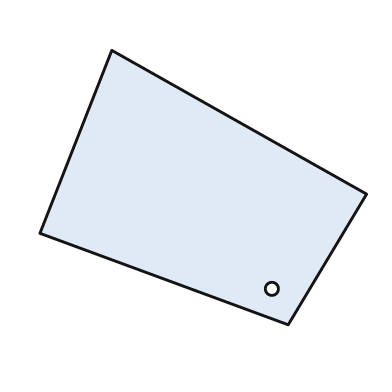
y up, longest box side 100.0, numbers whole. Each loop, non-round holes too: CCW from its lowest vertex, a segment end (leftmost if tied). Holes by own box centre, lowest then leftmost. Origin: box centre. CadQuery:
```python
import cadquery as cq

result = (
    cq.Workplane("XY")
    .moveTo(26.0, -42.0)
    .lineTo(50.0, -2.0)
    .lineTo(-28.0, 42.0)
    .lineTo(-50.0, -14.0)
    .close()
    .moveTo(21.0, -31.0)
    .circle(2.0)
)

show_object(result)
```